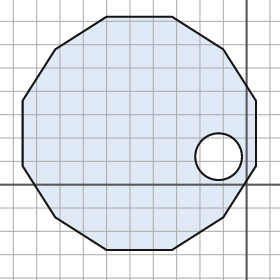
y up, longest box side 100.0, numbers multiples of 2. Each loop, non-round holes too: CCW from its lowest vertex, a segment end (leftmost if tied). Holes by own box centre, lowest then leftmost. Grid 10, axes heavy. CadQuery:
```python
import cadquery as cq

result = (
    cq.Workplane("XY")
    .moveTo(-60.0, -28.0)
    .lineTo(-32.0, -28.0)
    .lineTo(-10.0, -14.0)
    .lineTo(4.0, 8.0)
    .lineTo(4.0, 36.0)
    .lineTo(-10.0, 58.0)
    .lineTo(-32.0, 72.0)
    .lineTo(-60.0, 72.0)
    .lineTo(-82.0, 58.0)
    .lineTo(-96.0, 36.0)
    .lineTo(-96.0, 8.0)
    .lineTo(-82.0, -14.0)
    .close()
    .moveTo(-12.0, 12.0)
    .circle(10.0)
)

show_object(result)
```